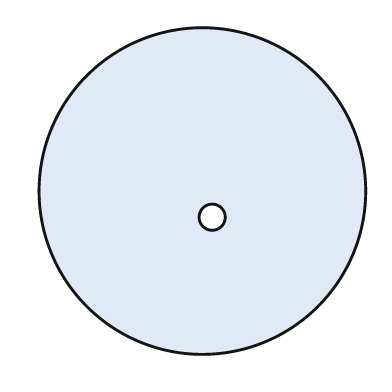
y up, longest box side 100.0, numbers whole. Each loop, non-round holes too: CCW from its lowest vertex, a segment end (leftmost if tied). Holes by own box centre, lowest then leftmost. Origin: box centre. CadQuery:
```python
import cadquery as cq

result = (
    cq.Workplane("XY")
    .moveTo(0.0, 0.0)
    .circle(50.0)
    .moveTo(3.0, -8.0)
    .circle(4.0)
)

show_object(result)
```